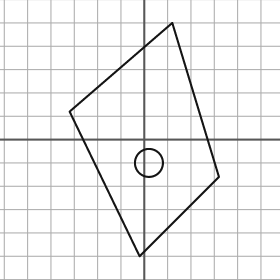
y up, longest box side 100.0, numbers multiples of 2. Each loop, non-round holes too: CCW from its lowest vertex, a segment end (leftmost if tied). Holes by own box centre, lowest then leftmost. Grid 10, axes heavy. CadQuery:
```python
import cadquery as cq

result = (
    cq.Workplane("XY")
    .moveTo(-2.0, -50.0)
    .lineTo(32.0, -16.0)
    .lineTo(12.0, 50.0)
    .lineTo(-32.0, 12.0)
    .close()
    .moveTo(2.0, -10.0)
    .circle(6.0)
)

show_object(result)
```